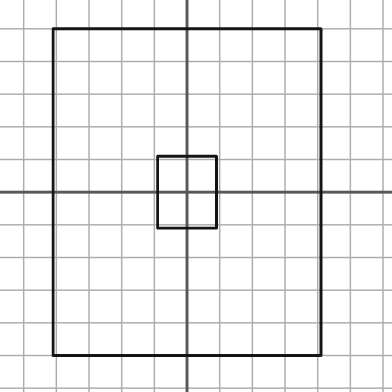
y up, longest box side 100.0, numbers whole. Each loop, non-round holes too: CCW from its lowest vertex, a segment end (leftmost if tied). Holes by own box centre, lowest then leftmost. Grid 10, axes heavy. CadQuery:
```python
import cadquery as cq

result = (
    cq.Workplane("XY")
    .moveTo(-41.0, -50.0)
    .lineTo(41.0, -50.0)
    .lineTo(41.0, 50.0)
    .lineTo(-41.0, 50.0)
    .close()
    .moveTo(-9.0, -11.0)
    .lineTo(9.0, -11.0)
    .lineTo(9.0, 11.0)
    .lineTo(-9.0, 11.0)
    .close()
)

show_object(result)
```